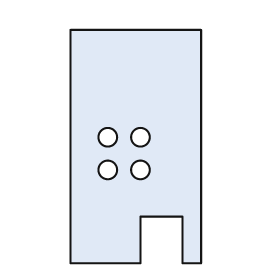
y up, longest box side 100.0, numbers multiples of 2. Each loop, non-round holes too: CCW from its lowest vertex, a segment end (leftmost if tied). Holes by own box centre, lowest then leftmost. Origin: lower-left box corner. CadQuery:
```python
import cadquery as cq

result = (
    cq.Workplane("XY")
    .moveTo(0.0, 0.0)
    .lineTo(30.0, 0.0)
    .lineTo(30.0, 20.0)
    .lineTo(48.0, 20.0)
    .lineTo(48.0, 0.0)
    .lineTo(56.0, 0.0)
    .lineTo(56.0, 100.0)
    .lineTo(0.0, 100.0)
    .close()
    .moveTo(16.0, 40.0)
    .circle(4.0)
    .moveTo(30.0, 40.0)
    .circle(4.0)
    .moveTo(16.0, 54.0)
    .circle(4.0)
    .moveTo(30.0, 54.0)
    .circle(4.0)
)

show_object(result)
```